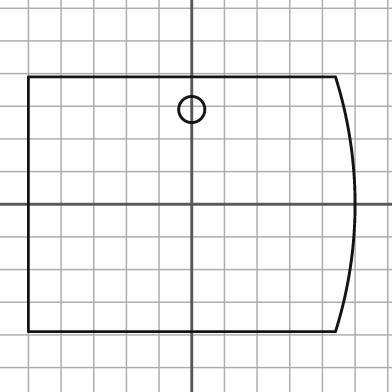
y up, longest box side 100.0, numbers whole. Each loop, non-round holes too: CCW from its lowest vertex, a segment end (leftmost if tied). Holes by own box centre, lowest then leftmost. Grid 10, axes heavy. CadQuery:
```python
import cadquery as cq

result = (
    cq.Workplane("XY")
    .moveTo(-50.0, -39.0)
    .lineTo(44.0, -39.0)
    .threePointArc((50.0, 0.0), (44.0, 39.0))
    .lineTo(-50.0, 39.0)
    .close()
    .moveTo(0.0, 29.0)
    .circle(4.0)
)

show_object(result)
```